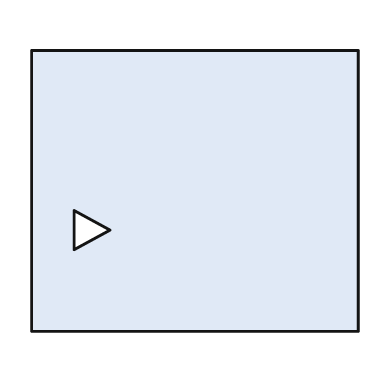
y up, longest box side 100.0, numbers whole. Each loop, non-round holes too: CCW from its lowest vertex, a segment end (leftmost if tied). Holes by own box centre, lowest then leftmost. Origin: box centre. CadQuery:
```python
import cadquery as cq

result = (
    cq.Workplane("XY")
    .moveTo(-50.0, -43.0)
    .lineTo(50.0, -43.0)
    .lineTo(50.0, 43.0)
    .lineTo(-50.0, 43.0)
    .close()
    .moveTo(-37.0, -18.0)
    .lineTo(-26.0, -12.0)
    .lineTo(-37.0, -6.0)
    .close()
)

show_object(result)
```